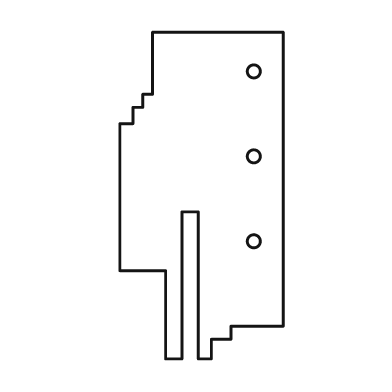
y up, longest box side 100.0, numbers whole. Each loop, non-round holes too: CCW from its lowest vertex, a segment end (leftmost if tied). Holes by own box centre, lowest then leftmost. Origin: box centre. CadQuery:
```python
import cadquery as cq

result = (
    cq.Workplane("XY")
    .moveTo(-11.0, -50.0)
    .lineTo(-6.0, -50.0)
    .lineTo(-6.0, -5.0)
    .lineTo(-1.0, -5.0)
    .lineTo(-1.0, -50.0)
    .lineTo(3.0, -50.0)
    .lineTo(3.0, -44.0)
    .lineTo(9.0, -44.0)
    .lineTo(9.0, -40.0)
    .lineTo(25.0, -40.0)
    .lineTo(25.0, 50.0)
    .lineTo(-15.0, 50.0)
    .lineTo(-15.0, 31.0)
    .lineTo(-18.0, 31.0)
    .lineTo(-18.0, 27.0)
    .lineTo(-21.0, 27.0)
    .lineTo(-21.0, 22.0)
    .lineTo(-25.0, 22.0)
    .lineTo(-25.0, -23.0)
    .lineTo(-11.0, -23.0)
    .close()
    .moveTo(16.0, -14.0)
    .circle(2.0)
    .moveTo(16.0, 12.0)
    .circle(2.0)
    .moveTo(16.0, 38.0)
    .circle(2.0)
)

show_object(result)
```